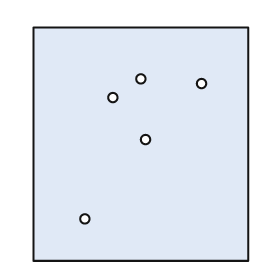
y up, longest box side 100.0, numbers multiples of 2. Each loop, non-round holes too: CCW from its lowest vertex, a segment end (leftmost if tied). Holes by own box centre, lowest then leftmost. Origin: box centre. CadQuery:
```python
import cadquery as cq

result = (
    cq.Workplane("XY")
    .moveTo(-46.0, -50.0)
    .lineTo(46.0, -50.0)
    .lineTo(46.0, 50.0)
    .lineTo(-46.0, 50.0)
    .close()
    .moveTo(-24.0, -32.0)
    .circle(2.0)
    .moveTo(2.0, 2.0)
    .circle(2.0)
    .moveTo(-12.0, 20.0)
    .circle(2.0)
    .moveTo(26.0, 26.0)
    .circle(2.0)
    .moveTo(0.0, 28.0)
    .circle(2.0)
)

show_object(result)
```